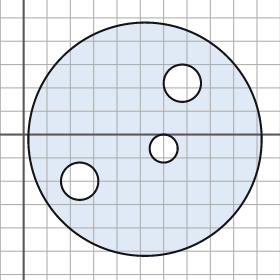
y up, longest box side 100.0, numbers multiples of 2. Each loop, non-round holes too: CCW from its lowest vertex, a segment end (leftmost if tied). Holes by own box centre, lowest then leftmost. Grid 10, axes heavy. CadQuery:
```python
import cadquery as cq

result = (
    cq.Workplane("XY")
    .moveTo(52.0, -2.0)
    .circle(50.0)
    .moveTo(24.0, -20.0)
    .circle(8.0)
    .moveTo(60.0, -6.0)
    .circle(6.0)
    .moveTo(68.0, 22.0)
    .circle(8.0)
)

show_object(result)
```